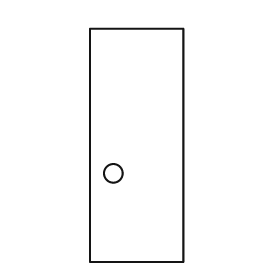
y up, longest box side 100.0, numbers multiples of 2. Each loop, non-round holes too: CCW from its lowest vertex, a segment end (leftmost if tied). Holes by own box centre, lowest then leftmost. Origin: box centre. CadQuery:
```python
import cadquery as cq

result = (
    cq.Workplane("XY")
    .moveTo(-20.0, -50.0)
    .lineTo(20.0, -50.0)
    .lineTo(20.0, 50.0)
    .lineTo(-20.0, 50.0)
    .close()
    .moveTo(-10.0, -12.0)
    .circle(4.0)
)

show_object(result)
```